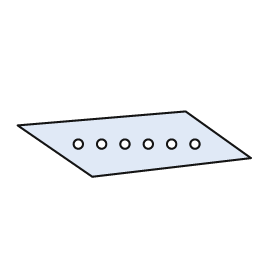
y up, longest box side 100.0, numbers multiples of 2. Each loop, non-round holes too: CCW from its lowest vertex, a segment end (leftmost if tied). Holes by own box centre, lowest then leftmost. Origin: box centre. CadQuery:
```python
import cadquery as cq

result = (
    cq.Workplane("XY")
    .moveTo(-18.0, -14.0)
    .lineTo(50.0, -6.0)
    .lineTo(22.0, 14.0)
    .lineTo(-50.0, 8.0)
    .close()
    .moveTo(-24.0, 0.0)
    .circle(2.0)
    .moveTo(-14.0, 0.0)
    .circle(2.0)
    .moveTo(-4.0, 0.0)
    .circle(2.0)
    .moveTo(6.0, 0.0)
    .circle(2.0)
    .moveTo(16.0, 0.0)
    .circle(2.0)
    .moveTo(26.0, 0.0)
    .circle(2.0)
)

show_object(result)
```